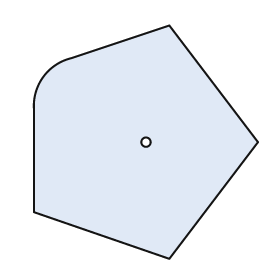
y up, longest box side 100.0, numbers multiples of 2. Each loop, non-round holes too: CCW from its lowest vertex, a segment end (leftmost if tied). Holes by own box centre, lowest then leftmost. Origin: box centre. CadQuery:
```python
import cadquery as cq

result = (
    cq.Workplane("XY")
    .moveTo(10.0, -50.0)
    .lineTo(48.0, 0.0)
    .lineTo(10.0, 50.0)
    .lineTo(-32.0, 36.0)
    .threePointArc((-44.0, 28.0), (-48.0, 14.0))
    .lineTo(-48.0, -30.0)
    .close()
    .moveTo(0.0, 0.0)
    .circle(2.0)
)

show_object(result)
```